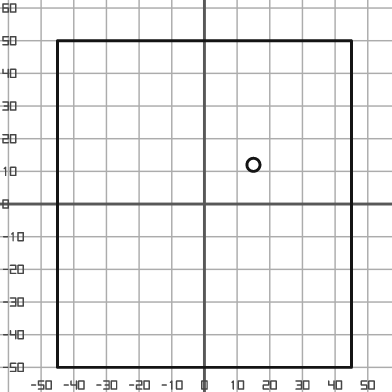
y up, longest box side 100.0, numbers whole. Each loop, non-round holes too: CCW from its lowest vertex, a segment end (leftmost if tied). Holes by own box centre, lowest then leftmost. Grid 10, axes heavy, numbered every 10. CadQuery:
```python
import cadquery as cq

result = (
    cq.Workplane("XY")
    .moveTo(-45.0, -50.0)
    .lineTo(45.0, -50.0)
    .lineTo(45.0, 50.0)
    .lineTo(-45.0, 50.0)
    .close()
    .moveTo(15.0, 12.0)
    .circle(2.0)
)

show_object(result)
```